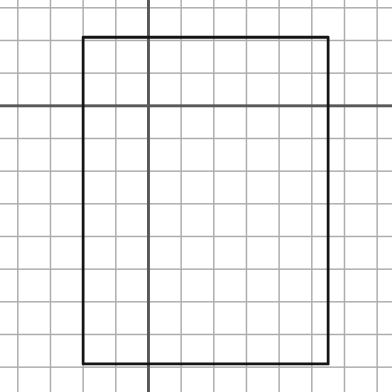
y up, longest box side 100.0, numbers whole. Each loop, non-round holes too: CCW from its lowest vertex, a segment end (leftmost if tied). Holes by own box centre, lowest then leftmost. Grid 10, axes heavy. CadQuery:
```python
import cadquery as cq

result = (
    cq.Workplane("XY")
    .moveTo(-20.0, -79.0)
    .lineTo(55.0, -79.0)
    .lineTo(55.0, 21.0)
    .lineTo(-20.0, 21.0)
    .close()
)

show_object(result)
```